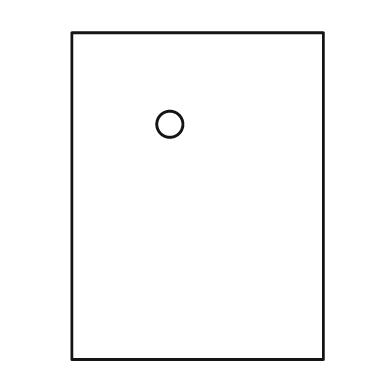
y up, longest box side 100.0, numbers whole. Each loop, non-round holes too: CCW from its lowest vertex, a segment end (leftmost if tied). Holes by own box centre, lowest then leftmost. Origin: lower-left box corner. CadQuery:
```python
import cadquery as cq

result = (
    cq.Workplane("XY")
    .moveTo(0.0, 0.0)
    .lineTo(77.0, 0.0)
    .lineTo(77.0, 100.0)
    .lineTo(0.0, 100.0)
    .close()
    .moveTo(30.0, 72.0)
    .circle(4.0)
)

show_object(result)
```